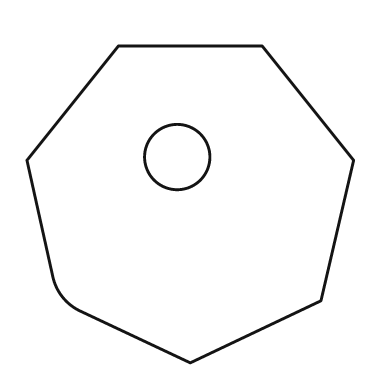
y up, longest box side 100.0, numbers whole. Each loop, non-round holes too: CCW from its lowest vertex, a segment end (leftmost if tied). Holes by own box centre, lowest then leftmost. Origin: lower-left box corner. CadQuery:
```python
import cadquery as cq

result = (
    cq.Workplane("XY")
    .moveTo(50.0, 0.0)
    .lineTo(90.0, 19.0)
    .lineTo(100.0, 62.0)
    .lineTo(72.0, 97.0)
    .lineTo(28.0, 97.0)
    .lineTo(0.0, 62.0)
    .lineTo(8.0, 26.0)
    .threePointArc((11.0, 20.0), (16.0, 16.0))
    .close()
    .moveTo(46.0, 63.0)
    .circle(10.0)
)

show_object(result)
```